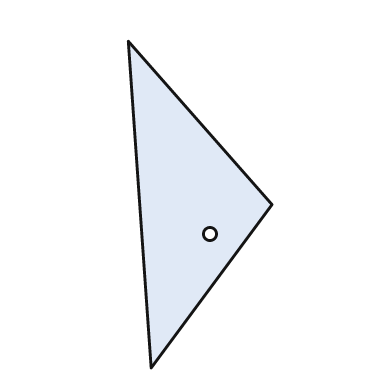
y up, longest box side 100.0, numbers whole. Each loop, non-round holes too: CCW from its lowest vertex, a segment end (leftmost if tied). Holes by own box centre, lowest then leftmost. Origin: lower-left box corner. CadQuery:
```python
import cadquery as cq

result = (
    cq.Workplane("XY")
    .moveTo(7.0, 0.0)
    .lineTo(44.0, 50.0)
    .lineTo(0.0, 100.0)
    .close()
    .moveTo(25.0, 41.0)
    .circle(2.0)
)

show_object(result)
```